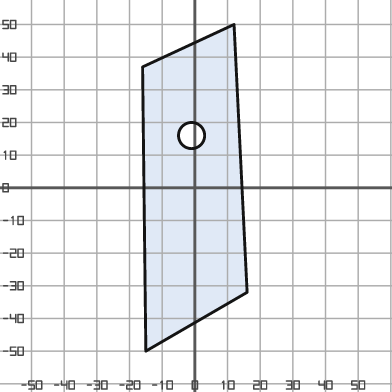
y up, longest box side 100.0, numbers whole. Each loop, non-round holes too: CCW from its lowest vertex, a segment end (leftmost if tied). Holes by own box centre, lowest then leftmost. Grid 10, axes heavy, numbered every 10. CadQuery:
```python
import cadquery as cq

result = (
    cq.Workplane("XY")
    .moveTo(-15.0, -50.0)
    .lineTo(16.0, -32.0)
    .lineTo(12.0, 50.0)
    .lineTo(-16.0, 37.0)
    .close()
    .moveTo(-1.0, 16.0)
    .circle(4.0)
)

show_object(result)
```